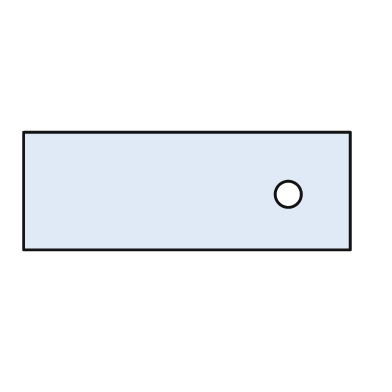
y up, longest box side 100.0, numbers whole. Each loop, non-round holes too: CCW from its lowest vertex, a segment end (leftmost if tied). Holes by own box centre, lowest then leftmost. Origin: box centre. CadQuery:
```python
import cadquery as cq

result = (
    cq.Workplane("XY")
    .moveTo(-50.0, -18.0)
    .lineTo(50.0, -18.0)
    .lineTo(50.0, 18.0)
    .lineTo(-50.0, 18.0)
    .close()
    .moveTo(31.0, -1.0)
    .circle(4.0)
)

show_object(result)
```